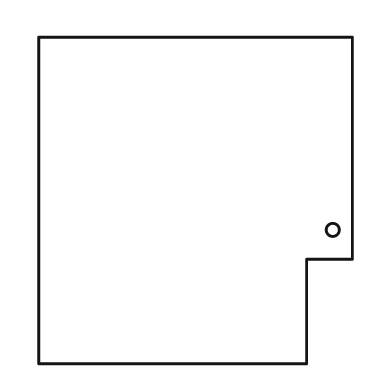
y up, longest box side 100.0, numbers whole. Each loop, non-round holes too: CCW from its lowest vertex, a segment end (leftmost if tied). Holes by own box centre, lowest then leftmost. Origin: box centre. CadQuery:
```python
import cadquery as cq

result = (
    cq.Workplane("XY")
    .moveTo(-48.0, -50.0)
    .lineTo(34.0, -50.0)
    .lineTo(34.0, -18.0)
    .lineTo(48.0, -18.0)
    .lineTo(48.0, 50.0)
    .lineTo(-48.0, 50.0)
    .close()
    .moveTo(42.0, -9.0)
    .circle(2.0)
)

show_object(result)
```